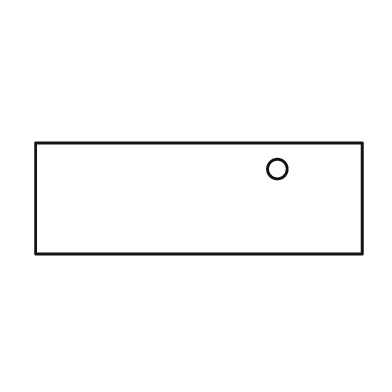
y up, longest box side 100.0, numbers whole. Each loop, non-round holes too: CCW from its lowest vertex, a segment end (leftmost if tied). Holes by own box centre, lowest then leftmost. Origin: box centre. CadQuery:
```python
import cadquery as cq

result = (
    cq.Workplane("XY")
    .moveTo(-50.0, -17.0)
    .lineTo(50.0, -17.0)
    .lineTo(50.0, 17.0)
    .lineTo(-50.0, 17.0)
    .close()
    .moveTo(24.0, 9.0)
    .circle(3.0)
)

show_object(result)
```